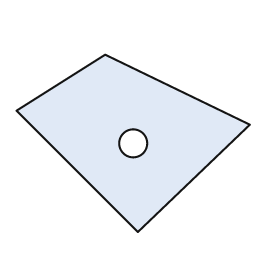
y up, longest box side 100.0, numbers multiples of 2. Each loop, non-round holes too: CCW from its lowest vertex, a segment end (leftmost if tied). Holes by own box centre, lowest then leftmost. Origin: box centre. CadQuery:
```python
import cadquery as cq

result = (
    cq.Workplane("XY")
    .moveTo(2.0, -38.0)
    .lineTo(50.0, 8.0)
    .lineTo(-12.0, 38.0)
    .lineTo(-50.0, 14.0)
    .close()
    .moveTo(0.0, 0.0)
    .circle(6.0)
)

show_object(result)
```